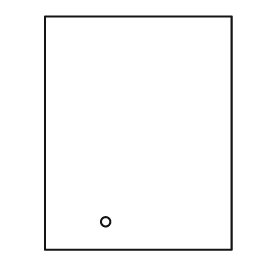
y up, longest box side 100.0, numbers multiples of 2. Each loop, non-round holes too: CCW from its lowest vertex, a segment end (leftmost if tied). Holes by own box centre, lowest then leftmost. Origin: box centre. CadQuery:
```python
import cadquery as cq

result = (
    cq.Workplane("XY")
    .moveTo(-40.0, -50.0)
    .lineTo(40.0, -50.0)
    .lineTo(40.0, 50.0)
    .lineTo(-40.0, 50.0)
    .close()
    .moveTo(-14.0, -38.0)
    .circle(2.0)
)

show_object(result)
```